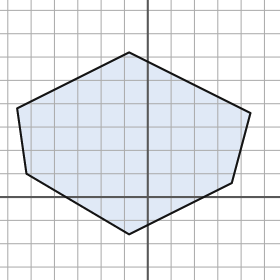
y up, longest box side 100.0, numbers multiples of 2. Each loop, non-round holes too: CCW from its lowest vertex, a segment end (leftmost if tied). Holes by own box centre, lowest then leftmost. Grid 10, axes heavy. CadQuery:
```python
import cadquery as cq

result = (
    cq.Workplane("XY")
    .moveTo(-8.0, -16.0)
    .lineTo(36.0, 6.0)
    .lineTo(44.0, 36.0)
    .lineTo(-8.0, 62.0)
    .lineTo(-56.0, 38.0)
    .lineTo(-52.0, 10.0)
    .close()
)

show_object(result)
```